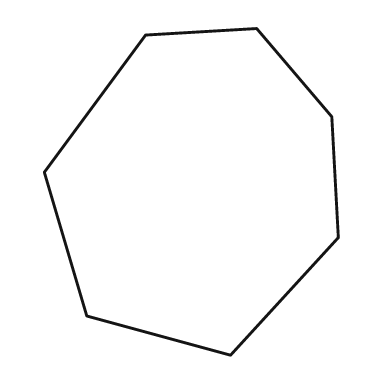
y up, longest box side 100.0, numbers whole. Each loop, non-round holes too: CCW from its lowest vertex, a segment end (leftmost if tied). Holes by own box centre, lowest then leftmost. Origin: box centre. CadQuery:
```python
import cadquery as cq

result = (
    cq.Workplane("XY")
    .moveTo(12.0, -50.0)
    .lineTo(45.0, -14.0)
    .lineTo(43.0, 23.0)
    .lineTo(20.0, 50.0)
    .lineTo(-14.0, 48.0)
    .lineTo(-45.0, 6.0)
    .lineTo(-32.0, -38.0)
    .close()
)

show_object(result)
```